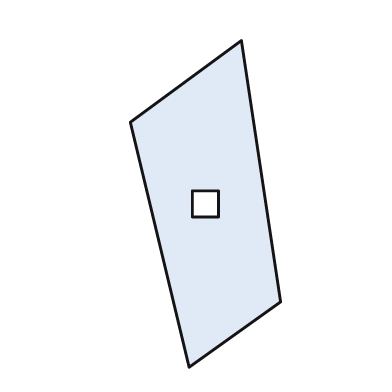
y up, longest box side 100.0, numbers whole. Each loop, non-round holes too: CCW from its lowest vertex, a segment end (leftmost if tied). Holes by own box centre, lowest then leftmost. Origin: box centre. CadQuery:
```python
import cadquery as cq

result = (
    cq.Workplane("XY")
    .moveTo(-5.0, -50.0)
    .lineTo(23.0, -30.0)
    .lineTo(11.0, 50.0)
    .lineTo(-23.0, 25.0)
    .close()
    .moveTo(-4.0, -4.0)
    .lineTo(4.0, -4.0)
    .lineTo(4.0, 4.0)
    .lineTo(-4.0, 4.0)
    .close()
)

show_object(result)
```